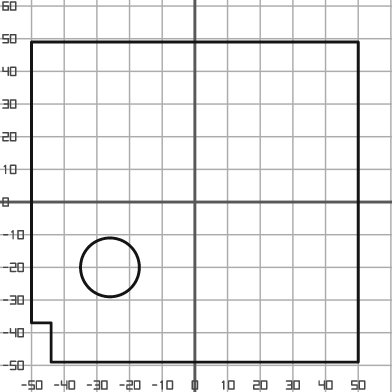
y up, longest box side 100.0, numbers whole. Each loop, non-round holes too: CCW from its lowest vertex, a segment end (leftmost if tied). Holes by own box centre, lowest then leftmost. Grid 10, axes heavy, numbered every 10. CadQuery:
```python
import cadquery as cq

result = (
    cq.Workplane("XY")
    .moveTo(-44.0, -49.0)
    .lineTo(50.0, -49.0)
    .lineTo(50.0, 49.0)
    .lineTo(-50.0, 49.0)
    .lineTo(-50.0, -37.0)
    .lineTo(-44.0, -37.0)
    .close()
    .moveTo(-26.0, -20.0)
    .circle(9.0)
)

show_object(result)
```